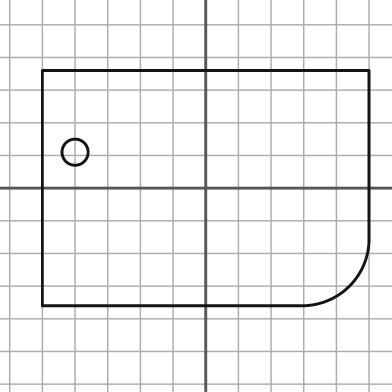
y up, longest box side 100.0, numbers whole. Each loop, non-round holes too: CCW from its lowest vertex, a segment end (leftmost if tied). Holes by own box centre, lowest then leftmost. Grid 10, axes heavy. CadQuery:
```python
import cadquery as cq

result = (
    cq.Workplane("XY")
    .moveTo(-50.0, -36.0)
    .lineTo(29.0, -36.0)
    .threePointArc((44.0, -30.0), (50.0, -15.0))
    .lineTo(50.0, 36.0)
    .lineTo(-50.0, 36.0)
    .close()
    .moveTo(-40.0, 11.0)
    .circle(4.0)
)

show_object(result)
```